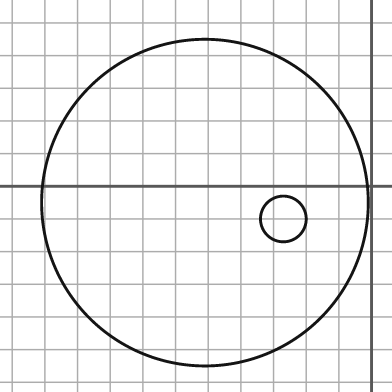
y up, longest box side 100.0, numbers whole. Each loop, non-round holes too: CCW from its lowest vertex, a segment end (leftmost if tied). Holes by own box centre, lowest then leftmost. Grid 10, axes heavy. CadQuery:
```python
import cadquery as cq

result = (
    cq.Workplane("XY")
    .moveTo(-51.0, -5.0)
    .circle(50.0)
    .moveTo(-27.0, -10.0)
    .circle(7.0)
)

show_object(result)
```